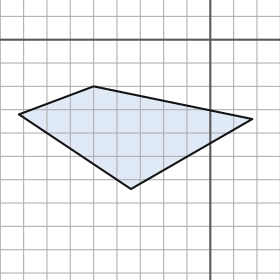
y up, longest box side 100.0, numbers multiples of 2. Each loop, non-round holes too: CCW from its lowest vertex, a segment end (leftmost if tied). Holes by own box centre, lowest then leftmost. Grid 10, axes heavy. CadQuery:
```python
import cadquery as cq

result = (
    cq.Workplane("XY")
    .moveTo(-34.0, -64.0)
    .lineTo(18.0, -34.0)
    .lineTo(-50.0, -20.0)
    .lineTo(-82.0, -32.0)
    .close()
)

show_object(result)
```